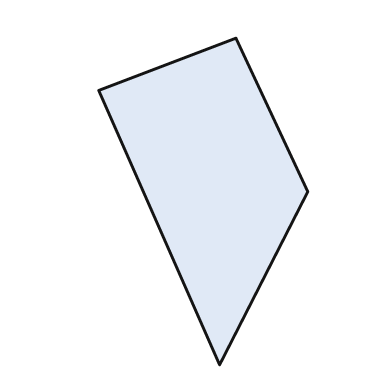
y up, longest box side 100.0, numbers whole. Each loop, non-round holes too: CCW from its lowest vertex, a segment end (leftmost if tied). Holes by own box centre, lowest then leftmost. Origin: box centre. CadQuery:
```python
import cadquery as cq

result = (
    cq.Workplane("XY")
    .moveTo(5.0, -50.0)
    .lineTo(32.0, 3.0)
    .lineTo(10.0, 50.0)
    .lineTo(-32.0, 34.0)
    .close()
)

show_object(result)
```